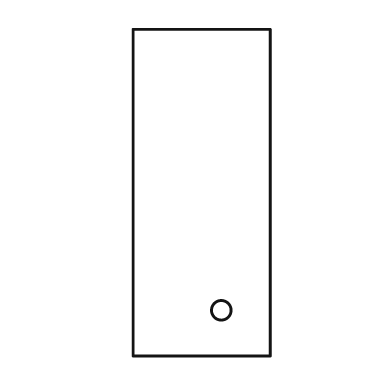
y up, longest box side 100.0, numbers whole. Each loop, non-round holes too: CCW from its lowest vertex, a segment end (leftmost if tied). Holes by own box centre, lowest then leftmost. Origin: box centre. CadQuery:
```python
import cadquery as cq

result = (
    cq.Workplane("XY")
    .moveTo(-21.0, -50.0)
    .lineTo(21.0, -50.0)
    .lineTo(21.0, 50.0)
    .lineTo(-21.0, 50.0)
    .close()
    .moveTo(6.0, -36.0)
    .circle(3.0)
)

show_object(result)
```